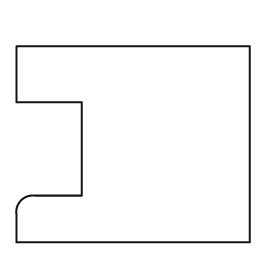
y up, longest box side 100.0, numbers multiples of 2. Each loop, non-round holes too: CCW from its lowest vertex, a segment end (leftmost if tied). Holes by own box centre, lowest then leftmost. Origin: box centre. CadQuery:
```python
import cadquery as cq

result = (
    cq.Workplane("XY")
    .moveTo(-50.0, -42.0)
    .lineTo(50.0, -42.0)
    .lineTo(50.0, 42.0)
    .lineTo(-50.0, 42.0)
    .lineTo(-50.0, 18.0)
    .lineTo(-22.0, 18.0)
    .lineTo(-22.0, -22.0)
    .lineTo(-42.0, -22.0)
    .threePointArc((-48.0, -24.0), (-50.0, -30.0))
    .close()
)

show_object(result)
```